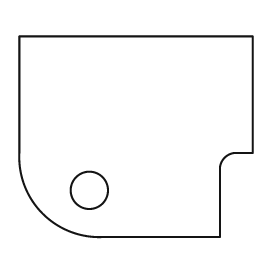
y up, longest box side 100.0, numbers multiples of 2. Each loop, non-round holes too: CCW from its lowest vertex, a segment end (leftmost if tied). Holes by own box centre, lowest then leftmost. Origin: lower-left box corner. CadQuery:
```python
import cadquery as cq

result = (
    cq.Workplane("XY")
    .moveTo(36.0, 0.0)
    .lineTo(86.0, 0.0)
    .lineTo(86.0, 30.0)
    .threePointArc((88.0, 34.0), (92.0, 36.0))
    .lineTo(100.0, 36.0)
    .lineTo(100.0, 86.0)
    .lineTo(0.0, 86.0)
    .lineTo(0.0, 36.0)
    .threePointArc((10.0, 10.0), (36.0, 0.0))
    .close()
    .moveTo(30.0, 20.0)
    .circle(8.0)
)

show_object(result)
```